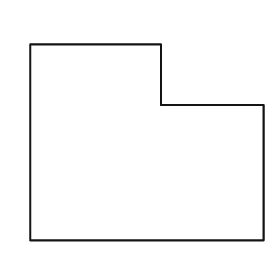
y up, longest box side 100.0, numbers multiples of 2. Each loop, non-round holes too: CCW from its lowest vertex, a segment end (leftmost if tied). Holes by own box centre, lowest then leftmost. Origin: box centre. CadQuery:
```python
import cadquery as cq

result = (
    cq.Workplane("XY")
    .moveTo(-50.0, -42.0)
    .lineTo(50.0, -42.0)
    .lineTo(50.0, 16.0)
    .lineTo(6.0, 16.0)
    .lineTo(6.0, 42.0)
    .lineTo(-50.0, 42.0)
    .close()
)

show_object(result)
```